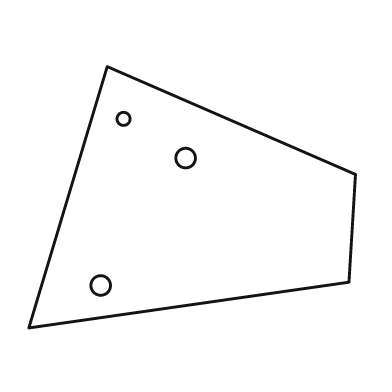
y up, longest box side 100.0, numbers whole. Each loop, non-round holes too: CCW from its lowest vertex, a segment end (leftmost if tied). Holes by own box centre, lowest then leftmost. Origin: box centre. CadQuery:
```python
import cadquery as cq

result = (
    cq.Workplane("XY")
    .moveTo(-50.0, -40.0)
    .lineTo(48.0, -26.0)
    .lineTo(50.0, 7.0)
    .lineTo(-26.0, 40.0)
    .close()
    .moveTo(-28.0, -27.0)
    .circle(3.0)
    .moveTo(-2.0, 12.0)
    .circle(3.0)
    .moveTo(-21.0, 24.0)
    .circle(2.0)
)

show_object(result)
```